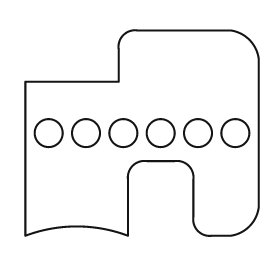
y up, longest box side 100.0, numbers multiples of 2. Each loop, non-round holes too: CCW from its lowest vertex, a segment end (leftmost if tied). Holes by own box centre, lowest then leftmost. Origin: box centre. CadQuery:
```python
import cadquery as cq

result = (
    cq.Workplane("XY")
    .moveTo(-50.0, -44.0)
    .threePointArc((-28.0, -40.0), (-6.0, -44.0))
    .lineTo(-6.0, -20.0)
    .threePointArc((-4.0, -14.0), (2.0, -12.0))
    .lineTo(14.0, -12.0)
    .threePointArc((20.0, -14.0), (22.0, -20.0))
    .lineTo(22.0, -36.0)
    .threePointArc((24.0, -42.0), (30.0, -44.0))
    .lineTo(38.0, -44.0)
    .threePointArc((46.0, -40.0), (50.0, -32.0))
    .lineTo(50.0, 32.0)
    .threePointArc((46.0, 40.0), (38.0, 44.0))
    .lineTo(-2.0, 44.0)
    .threePointArc((-8.0, 42.0), (-10.0, 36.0))
    .lineTo(-10.0, 22.0)
    .lineTo(-50.0, 22.0)
    .close()
    .moveTo(-40.0, 0.0)
    .circle(6.0)
    .moveTo(-24.0, 0.0)
    .circle(6.0)
    .moveTo(-8.0, 0.0)
    .circle(6.0)
    .moveTo(8.0, 0.0)
    .circle(6.0)
    .moveTo(24.0, 0.0)
    .circle(6.0)
    .moveTo(40.0, 0.0)
    .circle(6.0)
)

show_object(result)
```